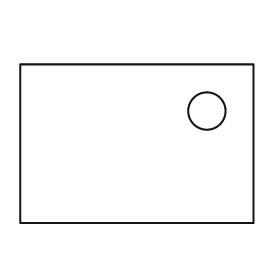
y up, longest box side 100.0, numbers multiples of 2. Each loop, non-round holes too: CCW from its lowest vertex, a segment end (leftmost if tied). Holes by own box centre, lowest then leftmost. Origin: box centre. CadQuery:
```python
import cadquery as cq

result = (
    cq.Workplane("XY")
    .moveTo(-50.0, -34.0)
    .lineTo(50.0, -34.0)
    .lineTo(50.0, 34.0)
    .lineTo(-50.0, 34.0)
    .close()
    .moveTo(30.0, 14.0)
    .circle(8.0)
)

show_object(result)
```